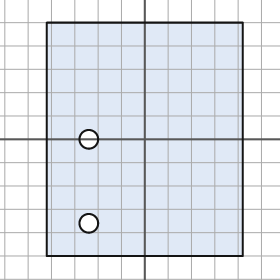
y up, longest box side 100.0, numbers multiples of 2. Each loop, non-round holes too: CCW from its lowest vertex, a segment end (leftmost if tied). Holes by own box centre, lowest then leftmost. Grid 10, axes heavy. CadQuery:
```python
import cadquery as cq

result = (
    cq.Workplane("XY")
    .moveTo(-42.0, -50.0)
    .lineTo(42.0, -50.0)
    .lineTo(42.0, 50.0)
    .lineTo(-42.0, 50.0)
    .close()
    .moveTo(-24.0, -36.0)
    .circle(4.0)
    .moveTo(-24.0, 0.0)
    .circle(4.0)
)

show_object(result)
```